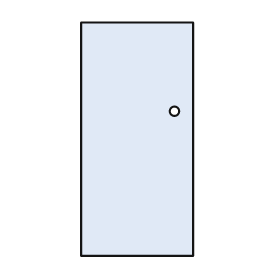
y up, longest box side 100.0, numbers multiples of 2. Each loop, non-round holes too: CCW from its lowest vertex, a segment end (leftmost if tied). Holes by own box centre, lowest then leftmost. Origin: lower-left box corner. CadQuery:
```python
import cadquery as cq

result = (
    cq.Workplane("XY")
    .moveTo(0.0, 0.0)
    .lineTo(48.0, 0.0)
    .lineTo(48.0, 100.0)
    .lineTo(0.0, 100.0)
    .close()
    .moveTo(40.0, 62.0)
    .circle(2.0)
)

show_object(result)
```